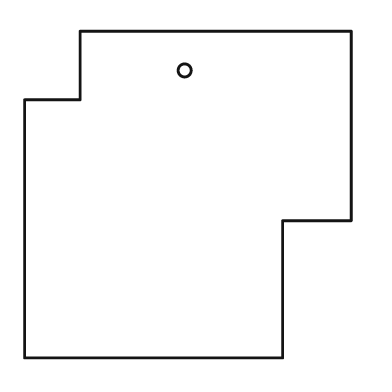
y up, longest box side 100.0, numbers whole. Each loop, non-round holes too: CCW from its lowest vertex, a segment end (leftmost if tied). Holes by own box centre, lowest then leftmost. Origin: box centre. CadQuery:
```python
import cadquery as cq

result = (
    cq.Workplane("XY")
    .moveTo(-50.0, -50.0)
    .lineTo(29.0, -50.0)
    .lineTo(29.0, -8.0)
    .lineTo(50.0, -8.0)
    .lineTo(50.0, 50.0)
    .lineTo(-33.0, 50.0)
    .lineTo(-33.0, 29.0)
    .lineTo(-50.0, 29.0)
    .close()
    .moveTo(-1.0, 38.0)
    .circle(2.0)
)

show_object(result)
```